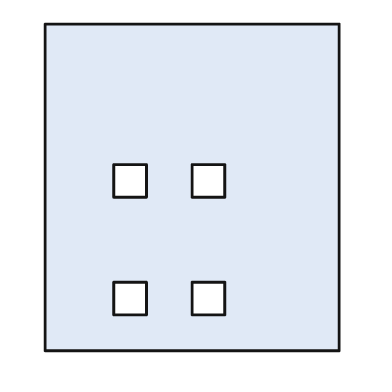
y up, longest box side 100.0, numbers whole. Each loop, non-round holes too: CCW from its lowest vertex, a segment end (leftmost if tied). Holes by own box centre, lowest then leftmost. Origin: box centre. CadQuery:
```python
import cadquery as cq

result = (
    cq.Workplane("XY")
    .moveTo(-45.0, -50.0)
    .lineTo(45.0, -50.0)
    .lineTo(45.0, 50.0)
    .lineTo(-45.0, 50.0)
    .close()
    .moveTo(-24.0, -39.0)
    .lineTo(-14.0, -39.0)
    .lineTo(-14.0, -29.0)
    .lineTo(-24.0, -29.0)
    .close()
    .moveTo(0.0, -39.0)
    .lineTo(10.0, -39.0)
    .lineTo(10.0, -29.0)
    .lineTo(0.0, -29.0)
    .close()
    .moveTo(-24.0, -3.0)
    .lineTo(-14.0, -3.0)
    .lineTo(-14.0, 7.0)
    .lineTo(-24.0, 7.0)
    .close()
    .moveTo(0.0, -3.0)
    .lineTo(10.0, -3.0)
    .lineTo(10.0, 7.0)
    .lineTo(0.0, 7.0)
    .close()
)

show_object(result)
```